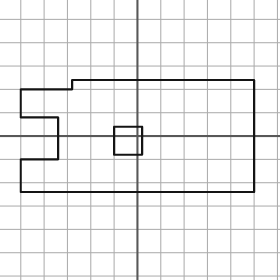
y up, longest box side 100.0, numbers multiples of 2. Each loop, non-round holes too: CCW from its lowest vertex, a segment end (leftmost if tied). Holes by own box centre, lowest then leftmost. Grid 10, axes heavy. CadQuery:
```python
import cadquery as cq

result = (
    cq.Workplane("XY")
    .moveTo(-50.0, -24.0)
    .lineTo(50.0, -24.0)
    .lineTo(50.0, 24.0)
    .lineTo(-28.0, 24.0)
    .lineTo(-28.0, 20.0)
    .lineTo(-50.0, 20.0)
    .lineTo(-50.0, 8.0)
    .lineTo(-34.0, 8.0)
    .lineTo(-34.0, -10.0)
    .lineTo(-50.0, -10.0)
    .close()
    .moveTo(-10.0, -8.0)
    .lineTo(2.0, -8.0)
    .lineTo(2.0, 4.0)
    .lineTo(-10.0, 4.0)
    .close()
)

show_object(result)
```